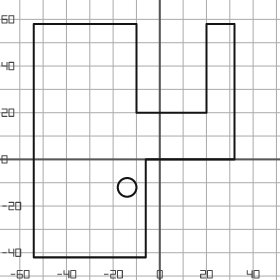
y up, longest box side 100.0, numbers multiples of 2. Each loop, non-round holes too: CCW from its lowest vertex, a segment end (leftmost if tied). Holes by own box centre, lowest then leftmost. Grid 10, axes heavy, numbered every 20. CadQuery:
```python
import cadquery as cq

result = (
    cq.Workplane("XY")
    .moveTo(-54.0, -42.0)
    .lineTo(-6.0, -42.0)
    .lineTo(-6.0, 0.0)
    .lineTo(32.0, 0.0)
    .lineTo(32.0, 58.0)
    .lineTo(20.0, 58.0)
    .lineTo(20.0, 20.0)
    .lineTo(-10.0, 20.0)
    .lineTo(-10.0, 58.0)
    .lineTo(-54.0, 58.0)
    .close()
    .moveTo(-14.0, -12.0)
    .circle(4.0)
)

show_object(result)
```